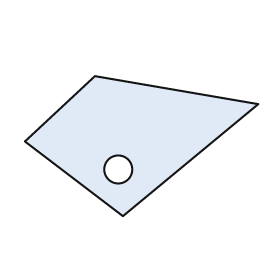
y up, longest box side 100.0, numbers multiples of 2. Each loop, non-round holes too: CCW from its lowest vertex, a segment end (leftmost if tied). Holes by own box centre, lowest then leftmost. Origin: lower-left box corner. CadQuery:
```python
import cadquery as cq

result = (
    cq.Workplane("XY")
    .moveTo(42.0, 0.0)
    .lineTo(100.0, 48.0)
    .lineTo(30.0, 60.0)
    .lineTo(0.0, 32.0)
    .close()
    .moveTo(40.0, 20.0)
    .circle(6.0)
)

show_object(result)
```